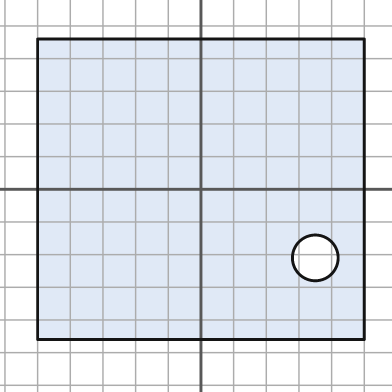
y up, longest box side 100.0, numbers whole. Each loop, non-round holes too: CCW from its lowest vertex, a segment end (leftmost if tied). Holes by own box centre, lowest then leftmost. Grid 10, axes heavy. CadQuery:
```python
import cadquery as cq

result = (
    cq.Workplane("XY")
    .moveTo(-50.0, -46.0)
    .lineTo(50.0, -46.0)
    .lineTo(50.0, 46.0)
    .lineTo(-50.0, 46.0)
    .close()
    .moveTo(35.0, -21.0)
    .circle(7.0)
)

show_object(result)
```